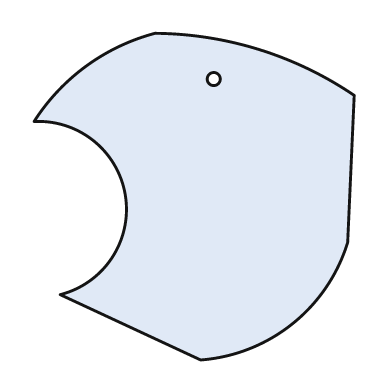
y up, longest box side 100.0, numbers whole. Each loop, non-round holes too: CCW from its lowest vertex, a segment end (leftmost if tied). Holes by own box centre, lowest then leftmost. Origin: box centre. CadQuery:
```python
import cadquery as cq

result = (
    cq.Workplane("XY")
    .moveTo(2.0, -50.0)
    .threePointArc((30.0, -39.0), (47.0, -14.0))
    .lineTo(49.0, 31.0)
    .threePointArc((20.0, 45.0), (-12.0, 50.0))
    .threePointArc((-33.0, 40.0), (-49.0, 23.0))
    .threePointArc((-21.0, 0.0), (-41.0, -30.0))
    .close()
    .moveTo(6.0, 36.0)
    .circle(2.0)
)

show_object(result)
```